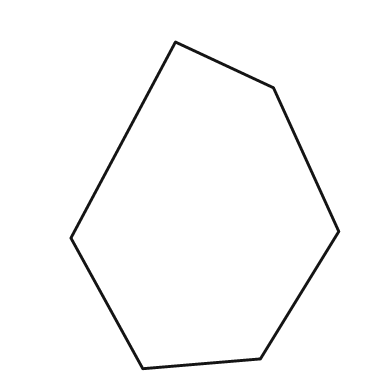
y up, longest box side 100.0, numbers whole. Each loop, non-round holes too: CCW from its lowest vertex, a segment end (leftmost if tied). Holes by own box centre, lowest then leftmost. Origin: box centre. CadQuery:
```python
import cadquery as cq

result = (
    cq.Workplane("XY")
    .moveTo(-19.0, -50.0)
    .lineTo(17.0, -47.0)
    .lineTo(41.0, -8.0)
    .lineTo(21.0, 36.0)
    .lineTo(-9.0, 50.0)
    .lineTo(-41.0, -10.0)
    .close()
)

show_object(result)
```